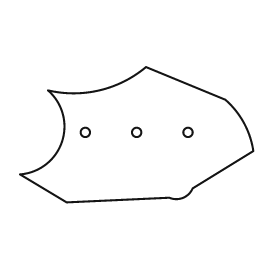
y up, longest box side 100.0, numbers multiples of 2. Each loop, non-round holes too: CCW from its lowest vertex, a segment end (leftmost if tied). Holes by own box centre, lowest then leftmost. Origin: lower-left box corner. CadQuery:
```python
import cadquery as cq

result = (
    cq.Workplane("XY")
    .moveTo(20.0, 0.0)
    .lineTo(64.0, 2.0)
    .threePointArc((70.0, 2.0), (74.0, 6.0))
    .lineTo(100.0, 22.0)
    .threePointArc((96.0, 34.0), (88.0, 44.0))
    .lineTo(54.0, 58.0)
    .threePointArc((34.0, 48.0), (12.0, 48.0))
    .threePointArc((18.0, 26.0), (0.0, 12.0))
    .close()
    .moveTo(28.0, 30.0)
    .circle(2.0)
    .moveTo(50.0, 30.0)
    .circle(2.0)
    .moveTo(72.0, 30.0)
    .circle(2.0)
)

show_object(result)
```